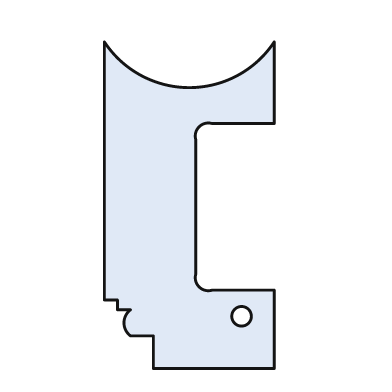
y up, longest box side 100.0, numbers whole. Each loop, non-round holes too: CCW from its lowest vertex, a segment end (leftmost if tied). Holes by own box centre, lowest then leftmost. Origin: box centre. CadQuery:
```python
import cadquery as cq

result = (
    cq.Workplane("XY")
    .moveTo(-11.0, -50.0)
    .lineTo(26.0, -50.0)
    .lineTo(26.0, -26.0)
    .lineTo(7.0, -26.0)
    .threePointArc((3.0, -25.0), (2.0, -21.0))
    .lineTo(2.0, 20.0)
    .threePointArc((3.0, 24.0), (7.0, 25.0))
    .lineTo(26.0, 25.0)
    .lineTo(26.0, 50.0)
    .threePointArc((0.0, 36.0), (-26.0, 50.0))
    .lineTo(-26.0, -29.0)
    .lineTo(-22.0, -29.0)
    .lineTo(-22.0, -32.0)
    .lineTo(-18.0, -32.0)
    .threePointArc((-20.0, -36.0), (-18.0, -40.0))
    .lineTo(-11.0, -40.0)
    .close()
    .moveTo(16.0, -34.0)
    .circle(3.0)
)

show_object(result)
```